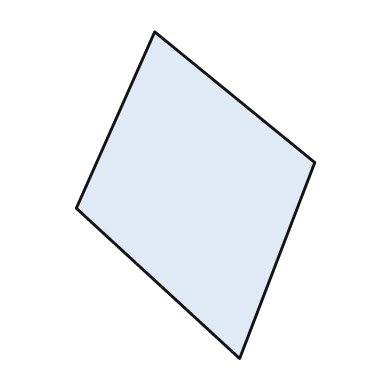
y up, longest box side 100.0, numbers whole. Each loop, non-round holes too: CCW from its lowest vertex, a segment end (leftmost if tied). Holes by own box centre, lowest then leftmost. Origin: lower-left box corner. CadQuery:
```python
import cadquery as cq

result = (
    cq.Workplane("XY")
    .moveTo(50.0, 0.0)
    .lineTo(73.0, 60.0)
    .lineTo(24.0, 100.0)
    .lineTo(0.0, 46.0)
    .close()
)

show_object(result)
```